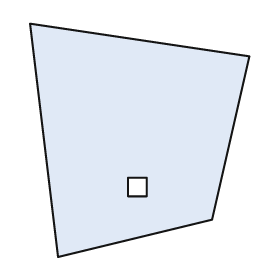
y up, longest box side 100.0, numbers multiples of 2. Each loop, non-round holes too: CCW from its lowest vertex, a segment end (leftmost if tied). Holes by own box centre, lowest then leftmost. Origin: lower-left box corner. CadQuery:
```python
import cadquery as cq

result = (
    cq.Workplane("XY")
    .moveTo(12.0, 0.0)
    .lineTo(78.0, 16.0)
    .lineTo(94.0, 86.0)
    .lineTo(0.0, 100.0)
    .close()
    .moveTo(42.0, 26.0)
    .lineTo(50.0, 26.0)
    .lineTo(50.0, 34.0)
    .lineTo(42.0, 34.0)
    .close()
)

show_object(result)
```